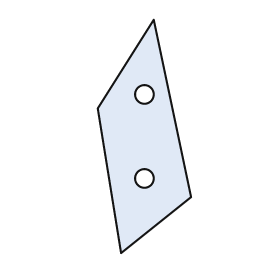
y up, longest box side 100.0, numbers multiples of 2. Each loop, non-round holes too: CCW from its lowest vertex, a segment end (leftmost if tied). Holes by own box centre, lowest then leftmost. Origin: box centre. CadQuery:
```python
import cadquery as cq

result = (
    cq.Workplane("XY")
    .moveTo(-10.0, -50.0)
    .lineTo(20.0, -26.0)
    .lineTo(4.0, 50.0)
    .lineTo(-20.0, 12.0)
    .close()
    .moveTo(0.0, -18.0)
    .circle(4.0)
    .moveTo(0.0, 18.0)
    .circle(4.0)
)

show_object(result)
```